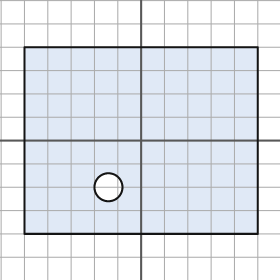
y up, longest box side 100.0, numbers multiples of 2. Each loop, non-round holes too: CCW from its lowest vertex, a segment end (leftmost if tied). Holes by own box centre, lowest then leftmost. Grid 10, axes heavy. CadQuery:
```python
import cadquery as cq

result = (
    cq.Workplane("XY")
    .moveTo(-50.0, -40.0)
    .lineTo(50.0, -40.0)
    .lineTo(50.0, 40.0)
    .lineTo(-50.0, 40.0)
    .close()
    .moveTo(-14.0, -20.0)
    .circle(6.0)
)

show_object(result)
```